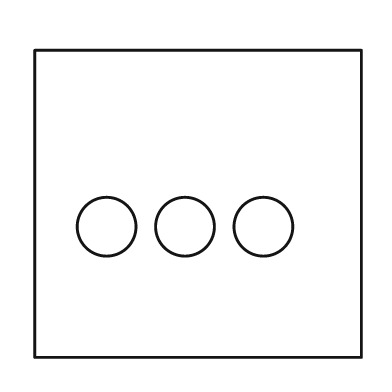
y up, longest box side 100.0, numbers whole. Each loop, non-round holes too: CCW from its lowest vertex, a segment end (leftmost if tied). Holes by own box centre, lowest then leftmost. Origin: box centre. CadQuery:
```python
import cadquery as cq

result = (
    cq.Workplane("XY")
    .moveTo(-50.0, -47.0)
    .lineTo(50.0, -47.0)
    .lineTo(50.0, 47.0)
    .lineTo(-50.0, 47.0)
    .close()
    .moveTo(-28.0, -7.0)
    .circle(9.0)
    .moveTo(-4.0, -7.0)
    .circle(9.0)
    .moveTo(20.0, -7.0)
    .circle(9.0)
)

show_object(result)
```